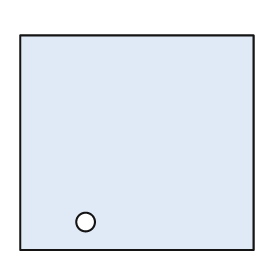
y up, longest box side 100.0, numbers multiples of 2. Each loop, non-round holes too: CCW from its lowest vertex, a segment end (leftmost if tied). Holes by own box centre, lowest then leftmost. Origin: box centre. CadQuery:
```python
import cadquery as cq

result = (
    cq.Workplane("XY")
    .moveTo(-50.0, -46.0)
    .lineTo(50.0, -46.0)
    .lineTo(50.0, 46.0)
    .lineTo(-50.0, 46.0)
    .close()
    .moveTo(-22.0, -34.0)
    .circle(4.0)
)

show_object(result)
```